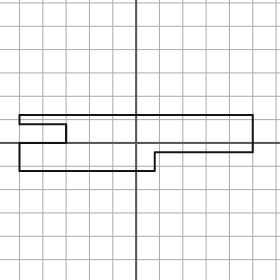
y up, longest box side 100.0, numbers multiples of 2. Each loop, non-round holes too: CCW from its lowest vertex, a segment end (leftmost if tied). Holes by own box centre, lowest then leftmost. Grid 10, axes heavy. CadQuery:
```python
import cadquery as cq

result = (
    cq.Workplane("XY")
    .moveTo(-50.0, -12.0)
    .lineTo(8.0, -12.0)
    .lineTo(8.0, -4.0)
    .lineTo(50.0, -4.0)
    .lineTo(50.0, 12.0)
    .lineTo(-50.0, 12.0)
    .lineTo(-50.0, 8.0)
    .lineTo(-30.0, 8.0)
    .lineTo(-30.0, 0.0)
    .lineTo(-50.0, 0.0)
    .close()
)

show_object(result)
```